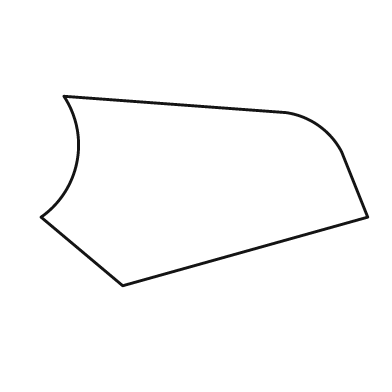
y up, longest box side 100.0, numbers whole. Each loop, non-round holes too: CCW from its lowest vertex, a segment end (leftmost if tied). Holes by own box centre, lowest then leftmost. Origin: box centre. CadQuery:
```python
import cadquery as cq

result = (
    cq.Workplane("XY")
    .moveTo(-25.0, -29.0)
    .lineTo(50.0, -8.0)
    .lineTo(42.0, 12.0)
    .threePointArc((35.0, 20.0), (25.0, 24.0))
    .lineTo(-43.0, 29.0)
    .threePointArc((-39.0, 9.0), (-50.0, -8.0))
    .close()
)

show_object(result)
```